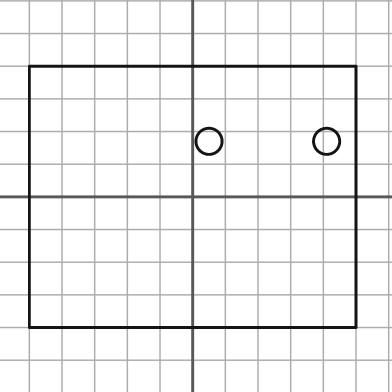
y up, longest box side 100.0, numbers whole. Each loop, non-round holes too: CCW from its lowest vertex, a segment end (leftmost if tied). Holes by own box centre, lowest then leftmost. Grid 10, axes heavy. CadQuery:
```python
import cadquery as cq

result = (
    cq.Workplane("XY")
    .moveTo(-50.0, -40.0)
    .lineTo(50.0, -40.0)
    .lineTo(50.0, 40.0)
    .lineTo(-50.0, 40.0)
    .close()
    .moveTo(5.0, 17.0)
    .circle(4.0)
    .moveTo(41.0, 17.0)
    .circle(4.0)
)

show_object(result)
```